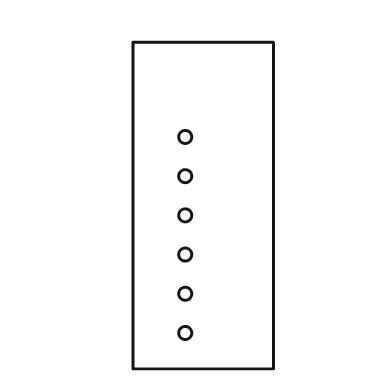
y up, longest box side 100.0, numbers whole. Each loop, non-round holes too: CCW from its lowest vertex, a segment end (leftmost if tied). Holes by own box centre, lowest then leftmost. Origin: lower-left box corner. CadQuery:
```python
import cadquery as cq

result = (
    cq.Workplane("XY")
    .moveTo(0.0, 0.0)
    .lineTo(43.0, 0.0)
    .lineTo(43.0, 100.0)
    .lineTo(0.0, 100.0)
    .close()
    .moveTo(16.0, 11.0)
    .circle(2.0)
    .moveTo(16.0, 23.0)
    .circle(2.0)
    .moveTo(16.0, 35.0)
    .circle(2.0)
    .moveTo(16.0, 47.0)
    .circle(2.0)
    .moveTo(16.0, 59.0)
    .circle(2.0)
    .moveTo(16.0, 71.0)
    .circle(2.0)
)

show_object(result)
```